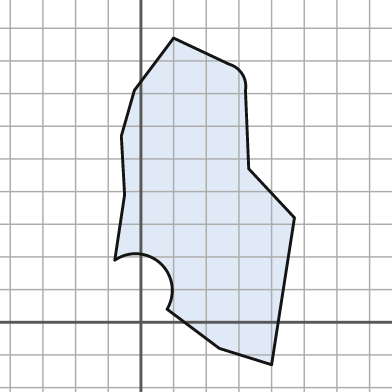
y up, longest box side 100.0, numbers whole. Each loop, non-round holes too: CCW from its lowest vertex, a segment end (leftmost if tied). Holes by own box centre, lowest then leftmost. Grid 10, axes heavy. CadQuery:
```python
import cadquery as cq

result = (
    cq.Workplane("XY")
    .moveTo(40.0, -13.0)
    .lineTo(47.0, 32.0)
    .lineTo(33.0, 47.0)
    .lineTo(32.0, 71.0)
    .threePointArc((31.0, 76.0), (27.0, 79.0))
    .lineTo(10.0, 87.0)
    .lineTo(-2.0, 71.0)
    .lineTo(-6.0, 57.0)
    .lineTo(-5.0, 39.0)
    .lineTo(-8.0, 19.0)
    .threePointArc((6.0, 18.0), (8.0, 4.0))
    .lineTo(24.0, -8.0)
    .close()
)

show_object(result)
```